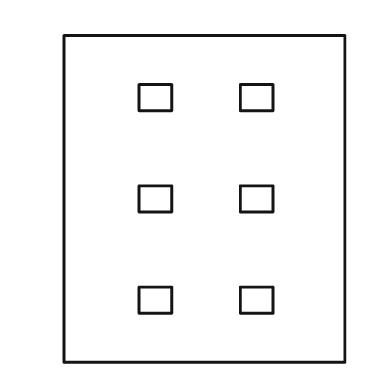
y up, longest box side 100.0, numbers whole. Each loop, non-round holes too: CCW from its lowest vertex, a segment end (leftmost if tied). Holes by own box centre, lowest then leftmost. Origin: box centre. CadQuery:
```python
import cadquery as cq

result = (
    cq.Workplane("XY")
    .moveTo(-43.0, -50.0)
    .lineTo(43.0, -50.0)
    .lineTo(43.0, 50.0)
    .lineTo(-43.0, 50.0)
    .close()
    .moveTo(-20.0, -35.0)
    .lineTo(-10.0, -35.0)
    .lineTo(-10.0, -27.0)
    .lineTo(-20.0, -27.0)
    .close()
    .moveTo(11.0, -35.0)
    .lineTo(21.0, -35.0)
    .lineTo(21.0, -27.0)
    .lineTo(11.0, -27.0)
    .close()
    .moveTo(-20.0, -4.0)
    .lineTo(-10.0, -4.0)
    .lineTo(-10.0, 4.0)
    .lineTo(-20.0, 4.0)
    .close()
    .moveTo(11.0, -4.0)
    .lineTo(21.0, -4.0)
    .lineTo(21.0, 4.0)
    .lineTo(11.0, 4.0)
    .close()
    .moveTo(-20.0, 27.0)
    .lineTo(-10.0, 27.0)
    .lineTo(-10.0, 35.0)
    .lineTo(-20.0, 35.0)
    .close()
    .moveTo(11.0, 27.0)
    .lineTo(21.0, 27.0)
    .lineTo(21.0, 35.0)
    .lineTo(11.0, 35.0)
    .close()
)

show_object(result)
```